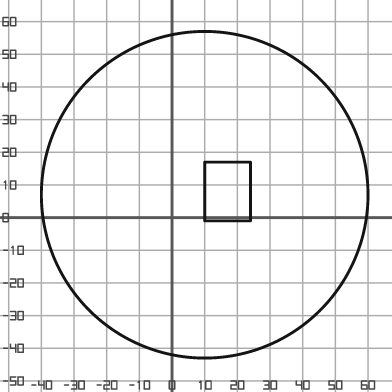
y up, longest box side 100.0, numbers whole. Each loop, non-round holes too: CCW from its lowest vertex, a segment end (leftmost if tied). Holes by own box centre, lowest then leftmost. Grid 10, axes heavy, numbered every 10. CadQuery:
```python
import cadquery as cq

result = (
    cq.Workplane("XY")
    .moveTo(10.0, 7.0)
    .circle(50.0)
    .moveTo(10.0, -1.0)
    .lineTo(24.0, -1.0)
    .lineTo(24.0, 17.0)
    .lineTo(10.0, 17.0)
    .close()
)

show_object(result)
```